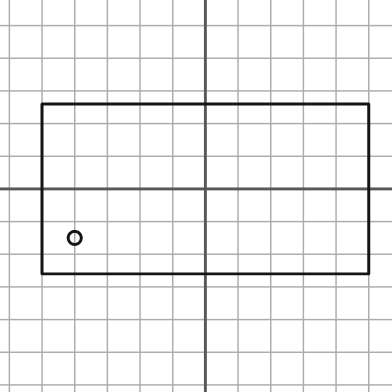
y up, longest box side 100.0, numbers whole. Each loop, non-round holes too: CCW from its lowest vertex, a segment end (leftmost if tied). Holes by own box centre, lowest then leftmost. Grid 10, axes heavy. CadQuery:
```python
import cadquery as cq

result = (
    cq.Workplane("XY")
    .moveTo(-50.0, -26.0)
    .lineTo(50.0, -26.0)
    .lineTo(50.0, 26.0)
    .lineTo(-50.0, 26.0)
    .close()
    .moveTo(-40.0, -15.0)
    .circle(2.0)
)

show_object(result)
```